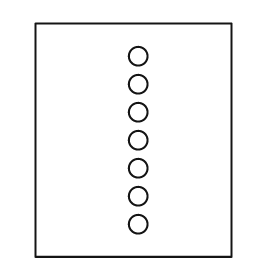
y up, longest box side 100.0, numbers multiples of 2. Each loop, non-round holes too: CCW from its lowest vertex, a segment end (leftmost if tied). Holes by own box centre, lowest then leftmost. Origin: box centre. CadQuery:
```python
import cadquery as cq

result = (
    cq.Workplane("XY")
    .moveTo(-42.0, -50.0)
    .lineTo(42.0, -50.0)
    .lineTo(42.0, 50.0)
    .lineTo(-42.0, 50.0)
    .close()
    .moveTo(2.0, -36.0)
    .circle(4.0)
    .moveTo(2.0, -24.0)
    .circle(4.0)
    .moveTo(2.0, -12.0)
    .circle(4.0)
    .moveTo(2.0, 0.0)
    .circle(4.0)
    .moveTo(2.0, 12.0)
    .circle(4.0)
    .moveTo(2.0, 24.0)
    .circle(4.0)
    .moveTo(2.0, 36.0)
    .circle(4.0)
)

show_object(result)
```